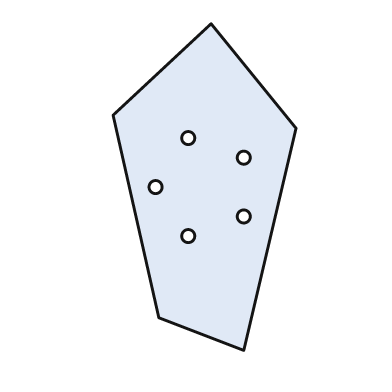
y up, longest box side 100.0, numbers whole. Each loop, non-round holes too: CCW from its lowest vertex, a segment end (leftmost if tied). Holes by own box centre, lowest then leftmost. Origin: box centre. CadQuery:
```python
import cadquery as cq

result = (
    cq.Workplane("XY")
    .moveTo(12.0, -50.0)
    .lineTo(28.0, 18.0)
    .lineTo(2.0, 50.0)
    .lineTo(-28.0, 22.0)
    .lineTo(-14.0, -40.0)
    .close()
    .moveTo(-5.0, -15.0)
    .circle(2.0)
    .moveTo(12.0, -9.0)
    .circle(2.0)
    .moveTo(-15.0, 0.0)
    .circle(2.0)
    .moveTo(12.0, 9.0)
    .circle(2.0)
    .moveTo(-5.0, 15.0)
    .circle(2.0)
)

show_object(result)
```